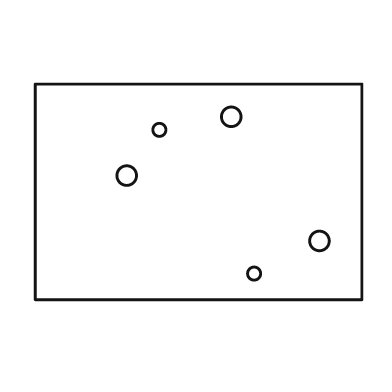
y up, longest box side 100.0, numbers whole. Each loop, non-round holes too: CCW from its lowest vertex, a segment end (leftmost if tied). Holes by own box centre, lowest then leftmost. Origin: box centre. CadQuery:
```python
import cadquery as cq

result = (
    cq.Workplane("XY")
    .moveTo(-50.0, -33.0)
    .lineTo(50.0, -33.0)
    .lineTo(50.0, 33.0)
    .lineTo(-50.0, 33.0)
    .close()
    .moveTo(17.0, -25.0)
    .circle(2.0)
    .moveTo(37.0, -15.0)
    .circle(3.0)
    .moveTo(-22.0, 5.0)
    .circle(3.0)
    .moveTo(-12.0, 19.0)
    .circle(2.0)
    .moveTo(10.0, 23.0)
    .circle(3.0)
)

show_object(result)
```